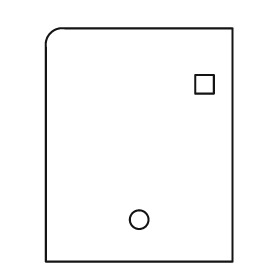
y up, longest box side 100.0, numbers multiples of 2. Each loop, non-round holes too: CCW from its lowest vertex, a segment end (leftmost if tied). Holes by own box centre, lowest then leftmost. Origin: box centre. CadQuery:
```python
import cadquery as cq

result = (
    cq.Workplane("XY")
    .moveTo(-40.0, -50.0)
    .lineTo(40.0, -50.0)
    .lineTo(40.0, 50.0)
    .lineTo(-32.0, 50.0)
    .threePointArc((-38.0, 48.0), (-40.0, 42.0))
    .close()
    .moveTo(0.0, -32.0)
    .circle(4.0)
    .moveTo(24.0, 22.0)
    .lineTo(32.0, 22.0)
    .lineTo(32.0, 30.0)
    .lineTo(24.0, 30.0)
    .close()
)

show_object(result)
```